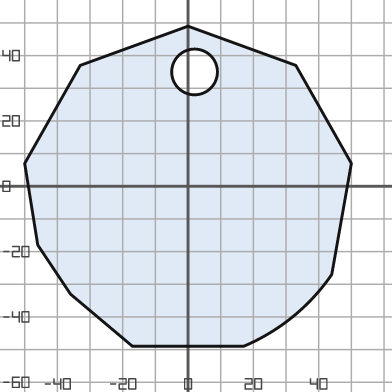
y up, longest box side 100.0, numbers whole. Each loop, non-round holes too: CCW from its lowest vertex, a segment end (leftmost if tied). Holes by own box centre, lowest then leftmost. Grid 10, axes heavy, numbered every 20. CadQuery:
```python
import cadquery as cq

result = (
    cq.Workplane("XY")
    .moveTo(-17.0, -49.0)
    .lineTo(17.0, -49.0)
    .threePointArc((32.0, -40.0), (44.0, -27.0))
    .lineTo(50.0, 7.0)
    .lineTo(33.0, 37.0)
    .lineTo(0.0, 49.0)
    .lineTo(-33.0, 37.0)
    .lineTo(-50.0, 7.0)
    .lineTo(-46.0, -18.0)
    .lineTo(-36.0, -33.0)
    .close()
    .moveTo(2.0, 35.0)
    .circle(7.0)
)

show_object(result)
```